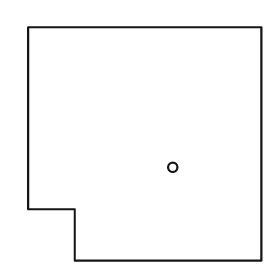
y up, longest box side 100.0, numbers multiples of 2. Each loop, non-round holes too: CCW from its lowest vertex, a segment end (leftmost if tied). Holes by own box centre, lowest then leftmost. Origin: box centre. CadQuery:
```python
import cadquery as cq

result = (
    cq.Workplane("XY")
    .moveTo(-30.0, -50.0)
    .lineTo(50.0, -50.0)
    .lineTo(50.0, 50.0)
    .lineTo(-50.0, 50.0)
    .lineTo(-50.0, -28.0)
    .lineTo(-30.0, -28.0)
    .close()
    .moveTo(12.0, -10.0)
    .circle(2.0)
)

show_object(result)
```